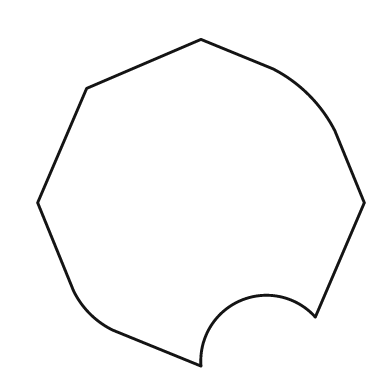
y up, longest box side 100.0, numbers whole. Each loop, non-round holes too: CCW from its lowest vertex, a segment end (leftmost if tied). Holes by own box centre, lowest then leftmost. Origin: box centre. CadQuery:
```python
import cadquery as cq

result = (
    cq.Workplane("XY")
    .moveTo(0.0, -50.0)
    .threePointArc((12.0, -30.0), (35.0, -35.0))
    .lineTo(50.0, 0.0)
    .lineTo(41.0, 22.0)
    .threePointArc((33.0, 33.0), (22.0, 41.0))
    .lineTo(0.0, 50.0)
    .lineTo(-35.0, 35.0)
    .lineTo(-50.0, 0.0)
    .lineTo(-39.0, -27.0)
    .threePointArc((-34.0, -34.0), (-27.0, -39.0))
    .close()
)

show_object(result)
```